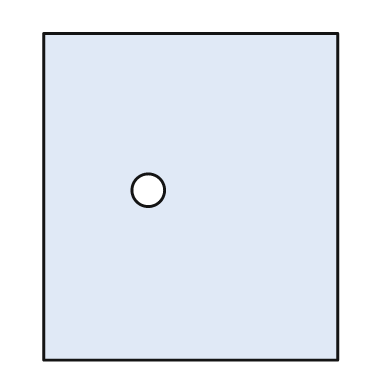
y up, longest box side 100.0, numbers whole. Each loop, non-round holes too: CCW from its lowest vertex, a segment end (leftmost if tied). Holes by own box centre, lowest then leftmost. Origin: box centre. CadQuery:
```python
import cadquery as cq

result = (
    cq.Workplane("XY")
    .moveTo(-45.0, -50.0)
    .lineTo(45.0, -50.0)
    .lineTo(45.0, 50.0)
    .lineTo(-45.0, 50.0)
    .close()
    .moveTo(-13.0, 2.0)
    .circle(5.0)
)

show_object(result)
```